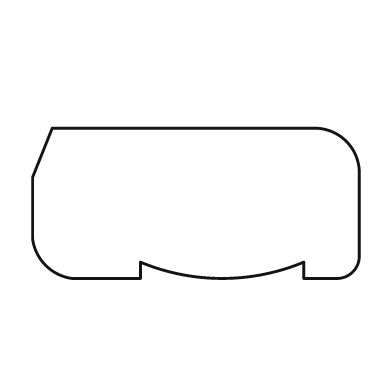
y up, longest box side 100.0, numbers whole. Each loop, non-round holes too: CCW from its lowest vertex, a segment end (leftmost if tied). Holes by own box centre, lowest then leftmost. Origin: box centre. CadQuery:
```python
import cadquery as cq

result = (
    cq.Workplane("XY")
    .moveTo(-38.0, -23.0)
    .lineTo(-17.0, -23.0)
    .lineTo(-17.0, -18.0)
    .threePointArc((8.0, -23.0), (33.0, -18.0))
    .lineTo(33.0, -23.0)
    .lineTo(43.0, -23.0)
    .threePointArc((48.0, -21.0), (50.0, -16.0))
    .lineTo(50.0, 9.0)
    .threePointArc((46.0, 19.0), (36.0, 23.0))
    .lineTo(-44.0, 23.0)
    .lineTo(-50.0, 8.0)
    .lineTo(-50.0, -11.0)
    .threePointArc((-46.0, -19.0), (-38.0, -23.0))
    .close()
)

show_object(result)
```